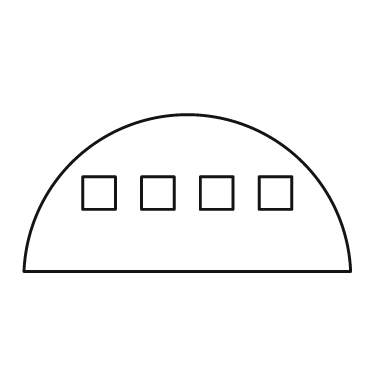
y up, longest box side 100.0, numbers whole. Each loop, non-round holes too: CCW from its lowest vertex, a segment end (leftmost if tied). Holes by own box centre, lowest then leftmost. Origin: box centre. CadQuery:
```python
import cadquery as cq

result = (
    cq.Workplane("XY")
    .moveTo(-50.0, -24.0)
    .lineTo(50.0, -24.0)
    .threePointArc((0.0, 24.0), (-50.0, -24.0))
    .close()
    .moveTo(-32.0, -5.0)
    .lineTo(-22.0, -5.0)
    .lineTo(-22.0, 5.0)
    .lineTo(-32.0, 5.0)
    .close()
    .moveTo(-14.0, -5.0)
    .lineTo(-4.0, -5.0)
    .lineTo(-4.0, 5.0)
    .lineTo(-14.0, 5.0)
    .close()
    .moveTo(4.0, -5.0)
    .lineTo(14.0, -5.0)
    .lineTo(14.0, 5.0)
    .lineTo(4.0, 5.0)
    .close()
    .moveTo(22.0, -5.0)
    .lineTo(32.0, -5.0)
    .lineTo(32.0, 5.0)
    .lineTo(22.0, 5.0)
    .close()
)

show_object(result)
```